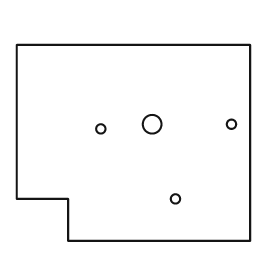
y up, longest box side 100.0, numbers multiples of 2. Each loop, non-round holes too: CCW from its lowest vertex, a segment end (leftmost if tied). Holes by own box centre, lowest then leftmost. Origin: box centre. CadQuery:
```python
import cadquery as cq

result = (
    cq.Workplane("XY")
    .moveTo(-28.0, -42.0)
    .lineTo(50.0, -42.0)
    .lineTo(50.0, 42.0)
    .lineTo(-50.0, 42.0)
    .lineTo(-50.0, -24.0)
    .lineTo(-28.0, -24.0)
    .close()
    .moveTo(18.0, -24.0)
    .circle(2.0)
    .moveTo(-14.0, 6.0)
    .circle(2.0)
    .moveTo(8.0, 8.0)
    .circle(4.0)
    .moveTo(42.0, 8.0)
    .circle(2.0)
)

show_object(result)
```